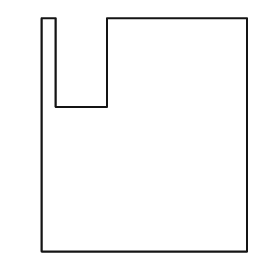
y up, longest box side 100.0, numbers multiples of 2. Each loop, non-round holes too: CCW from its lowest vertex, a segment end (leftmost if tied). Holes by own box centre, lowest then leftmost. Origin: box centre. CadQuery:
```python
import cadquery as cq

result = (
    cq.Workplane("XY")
    .moveTo(-44.0, -50.0)
    .lineTo(44.0, -50.0)
    .lineTo(44.0, 50.0)
    .lineTo(-16.0, 50.0)
    .lineTo(-16.0, 12.0)
    .lineTo(-38.0, 12.0)
    .lineTo(-38.0, 50.0)
    .lineTo(-44.0, 50.0)
    .close()
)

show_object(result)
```